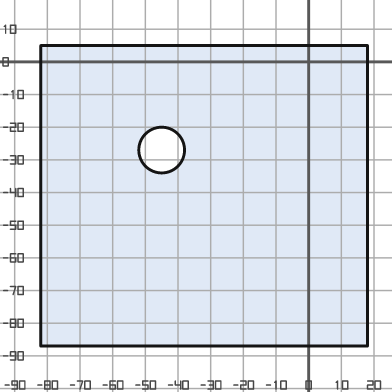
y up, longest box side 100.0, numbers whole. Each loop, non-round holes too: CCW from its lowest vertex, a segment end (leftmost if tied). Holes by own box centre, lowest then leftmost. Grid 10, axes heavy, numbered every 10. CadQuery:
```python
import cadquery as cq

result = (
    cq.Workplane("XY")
    .moveTo(-82.0, -87.0)
    .lineTo(18.0, -87.0)
    .lineTo(18.0, 5.0)
    .lineTo(-82.0, 5.0)
    .close()
    .moveTo(-45.0, -27.0)
    .circle(7.0)
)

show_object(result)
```